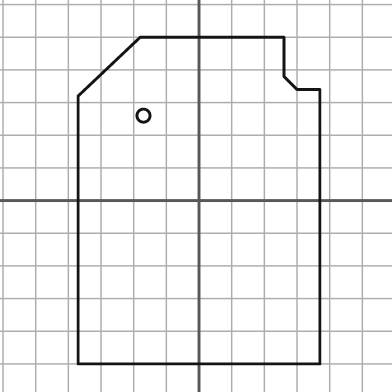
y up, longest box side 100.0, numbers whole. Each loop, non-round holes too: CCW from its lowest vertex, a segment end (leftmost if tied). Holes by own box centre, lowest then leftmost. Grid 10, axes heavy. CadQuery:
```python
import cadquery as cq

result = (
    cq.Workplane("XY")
    .moveTo(-37.0, -50.0)
    .lineTo(37.0, -50.0)
    .lineTo(37.0, 34.0)
    .lineTo(30.0, 34.0)
    .lineTo(26.0, 38.0)
    .lineTo(26.0, 50.0)
    .lineTo(-18.0, 50.0)
    .lineTo(-37.0, 32.0)
    .close()
    .moveTo(-17.0, 26.0)
    .circle(2.0)
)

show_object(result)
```